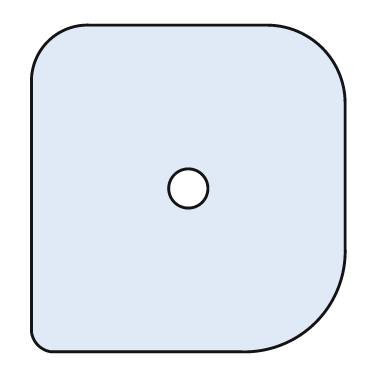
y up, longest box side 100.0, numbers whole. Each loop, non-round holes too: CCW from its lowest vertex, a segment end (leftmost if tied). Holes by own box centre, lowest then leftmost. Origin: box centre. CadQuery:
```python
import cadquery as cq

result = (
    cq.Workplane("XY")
    .moveTo(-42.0, -50.0)
    .lineTo(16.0, -50.0)
    .threePointArc((39.0, -41.0), (48.0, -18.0))
    .lineTo(48.0, 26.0)
    .threePointArc((41.0, 43.0), (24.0, 50.0))
    .lineTo(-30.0, 50.0)
    .threePointArc((-43.0, 45.0), (-48.0, 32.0))
    .lineTo(-48.0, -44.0)
    .threePointArc((-46.0, -48.0), (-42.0, -50.0))
    .close()
    .moveTo(0.0, 0.0)
    .circle(6.0)
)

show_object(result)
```